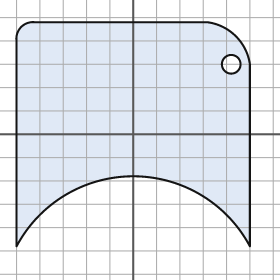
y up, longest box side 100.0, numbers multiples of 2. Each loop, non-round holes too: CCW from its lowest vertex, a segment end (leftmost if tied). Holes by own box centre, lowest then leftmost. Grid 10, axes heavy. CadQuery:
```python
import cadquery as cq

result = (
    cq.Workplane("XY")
    .moveTo(-50.0, -48.0)
    .threePointArc((0.0, -18.0), (50.0, -48.0))
    .lineTo(50.0, 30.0)
    .threePointArc((44.0, 42.0), (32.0, 48.0))
    .lineTo(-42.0, 48.0)
    .threePointArc((-48.0, 46.0), (-50.0, 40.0))
    .close()
    .moveTo(42.0, 30.0)
    .circle(4.0)
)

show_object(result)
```